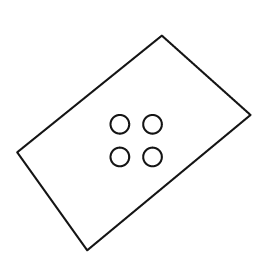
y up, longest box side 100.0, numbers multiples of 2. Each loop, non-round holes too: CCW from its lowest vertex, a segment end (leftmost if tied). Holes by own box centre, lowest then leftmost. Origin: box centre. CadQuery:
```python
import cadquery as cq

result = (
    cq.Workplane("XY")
    .moveTo(-20.0, -46.0)
    .lineTo(50.0, 12.0)
    .lineTo(12.0, 46.0)
    .lineTo(-50.0, -4.0)
    .close()
    .moveTo(-6.0, -6.0)
    .circle(4.0)
    .moveTo(8.0, -6.0)
    .circle(4.0)
    .moveTo(-6.0, 8.0)
    .circle(4.0)
    .moveTo(8.0, 8.0)
    .circle(4.0)
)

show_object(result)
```